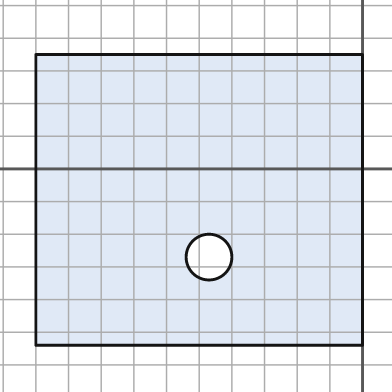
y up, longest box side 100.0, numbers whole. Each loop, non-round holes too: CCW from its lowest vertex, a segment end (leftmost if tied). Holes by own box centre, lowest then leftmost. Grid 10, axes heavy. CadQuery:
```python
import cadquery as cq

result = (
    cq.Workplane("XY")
    .moveTo(-100.0, -54.0)
    .lineTo(0.0, -54.0)
    .lineTo(0.0, 35.0)
    .lineTo(-100.0, 35.0)
    .close()
    .moveTo(-47.0, -27.0)
    .circle(7.0)
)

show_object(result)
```